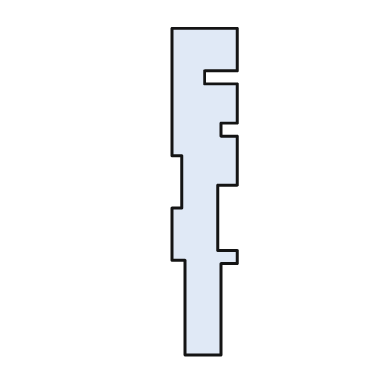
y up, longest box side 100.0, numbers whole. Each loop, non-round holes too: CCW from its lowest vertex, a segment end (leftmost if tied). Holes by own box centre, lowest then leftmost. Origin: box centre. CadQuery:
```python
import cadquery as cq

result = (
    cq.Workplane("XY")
    .moveTo(-6.0, -50.0)
    .lineTo(5.0, -50.0)
    .lineTo(5.0, -22.0)
    .lineTo(10.0, -22.0)
    .lineTo(10.0, -18.0)
    .lineTo(4.0, -18.0)
    .lineTo(4.0, 2.0)
    .lineTo(10.0, 2.0)
    .lineTo(10.0, 17.0)
    .lineTo(5.0, 17.0)
    .lineTo(5.0, 21.0)
    .lineTo(10.0, 21.0)
    .lineTo(10.0, 33.0)
    .lineTo(0.0, 33.0)
    .lineTo(0.0, 37.0)
    .lineTo(10.0, 37.0)
    .lineTo(10.0, 50.0)
    .lineTo(-10.0, 50.0)
    .lineTo(-10.0, 11.0)
    .lineTo(-7.0, 11.0)
    .lineTo(-7.0, -5.0)
    .lineTo(-10.0, -5.0)
    .lineTo(-10.0, -21.0)
    .lineTo(-6.0, -21.0)
    .close()
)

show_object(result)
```